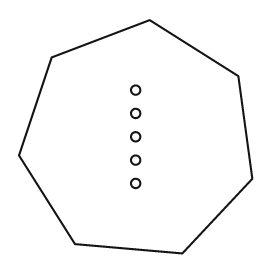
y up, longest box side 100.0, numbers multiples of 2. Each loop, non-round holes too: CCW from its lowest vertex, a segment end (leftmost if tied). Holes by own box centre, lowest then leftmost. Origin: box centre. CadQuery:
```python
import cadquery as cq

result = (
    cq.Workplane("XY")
    .moveTo(20.0, -50.0)
    .lineTo(50.0, -18.0)
    .lineTo(44.0, 26.0)
    .lineTo(6.0, 50.0)
    .lineTo(-36.0, 34.0)
    .lineTo(-50.0, -8.0)
    .lineTo(-26.0, -46.0)
    .close()
    .moveTo(0.0, -20.0)
    .circle(2.0)
    .moveTo(0.0, -10.0)
    .circle(2.0)
    .moveTo(0.0, 0.0)
    .circle(2.0)
    .moveTo(0.0, 10.0)
    .circle(2.0)
    .moveTo(0.0, 20.0)
    .circle(2.0)
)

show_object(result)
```